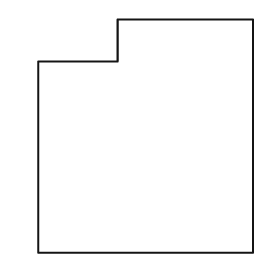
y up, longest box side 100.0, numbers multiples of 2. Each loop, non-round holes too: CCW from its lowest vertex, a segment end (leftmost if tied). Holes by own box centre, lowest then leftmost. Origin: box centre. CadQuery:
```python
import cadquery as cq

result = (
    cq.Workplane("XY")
    .moveTo(-46.0, -50.0)
    .lineTo(46.0, -50.0)
    .lineTo(46.0, 50.0)
    .lineTo(-12.0, 50.0)
    .lineTo(-12.0, 32.0)
    .lineTo(-46.0, 32.0)
    .close()
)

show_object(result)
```